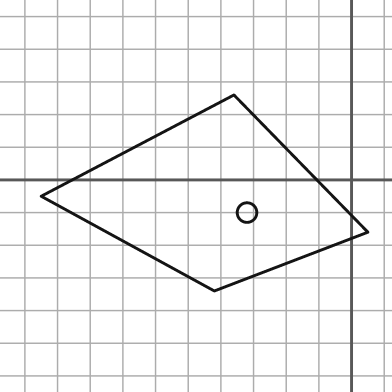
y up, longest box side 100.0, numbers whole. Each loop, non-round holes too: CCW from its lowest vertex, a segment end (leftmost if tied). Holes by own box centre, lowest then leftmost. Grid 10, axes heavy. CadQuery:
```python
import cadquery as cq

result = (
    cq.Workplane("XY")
    .moveTo(-42.0, -34.0)
    .lineTo(5.0, -16.0)
    .lineTo(-36.0, 26.0)
    .lineTo(-95.0, -5.0)
    .close()
    .moveTo(-32.0, -10.0)
    .circle(3.0)
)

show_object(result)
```